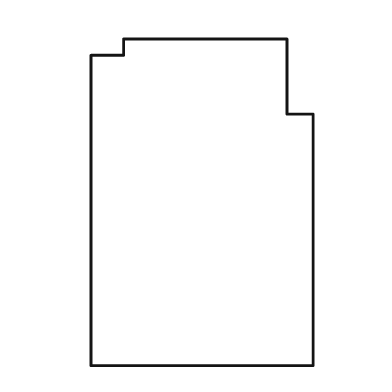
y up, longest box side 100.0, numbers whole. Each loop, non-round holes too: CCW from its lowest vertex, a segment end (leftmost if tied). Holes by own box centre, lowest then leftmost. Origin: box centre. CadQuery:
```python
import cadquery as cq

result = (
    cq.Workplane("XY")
    .moveTo(-34.0, -50.0)
    .lineTo(34.0, -50.0)
    .lineTo(34.0, 27.0)
    .lineTo(26.0, 27.0)
    .lineTo(26.0, 50.0)
    .lineTo(-24.0, 50.0)
    .lineTo(-24.0, 45.0)
    .lineTo(-34.0, 45.0)
    .close()
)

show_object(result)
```